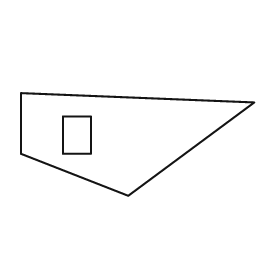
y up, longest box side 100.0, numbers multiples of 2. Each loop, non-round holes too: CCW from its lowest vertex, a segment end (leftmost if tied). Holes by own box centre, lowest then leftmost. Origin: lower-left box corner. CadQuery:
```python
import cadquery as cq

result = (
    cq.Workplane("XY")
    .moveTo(46.0, 0.0)
    .lineTo(100.0, 40.0)
    .lineTo(0.0, 44.0)
    .lineTo(0.0, 18.0)
    .close()
    .moveTo(18.0, 18.0)
    .lineTo(30.0, 18.0)
    .lineTo(30.0, 34.0)
    .lineTo(18.0, 34.0)
    .close()
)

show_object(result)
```